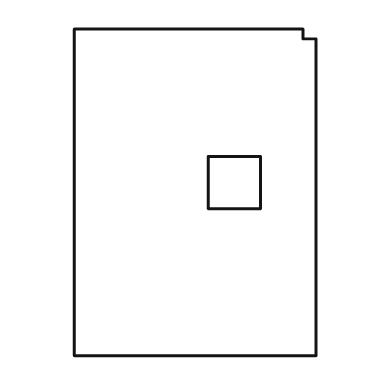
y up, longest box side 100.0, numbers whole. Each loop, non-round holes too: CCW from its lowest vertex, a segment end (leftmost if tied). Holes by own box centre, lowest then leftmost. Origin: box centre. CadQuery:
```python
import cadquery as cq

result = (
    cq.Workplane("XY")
    .moveTo(-37.0, -50.0)
    .lineTo(37.0, -50.0)
    .lineTo(37.0, 47.0)
    .lineTo(33.0, 47.0)
    .lineTo(33.0, 50.0)
    .lineTo(-37.0, 50.0)
    .close()
    .moveTo(4.0, -5.0)
    .lineTo(20.0, -5.0)
    .lineTo(20.0, 11.0)
    .lineTo(4.0, 11.0)
    .close()
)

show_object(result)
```